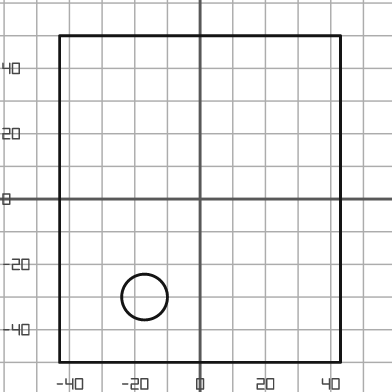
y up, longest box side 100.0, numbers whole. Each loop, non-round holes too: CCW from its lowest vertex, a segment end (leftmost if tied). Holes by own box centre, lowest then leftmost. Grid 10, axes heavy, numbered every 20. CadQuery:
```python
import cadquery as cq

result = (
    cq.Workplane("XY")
    .moveTo(-43.0, -50.0)
    .lineTo(43.0, -50.0)
    .lineTo(43.0, 50.0)
    .lineTo(-43.0, 50.0)
    .close()
    .moveTo(-17.0, -30.0)
    .circle(7.0)
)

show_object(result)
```